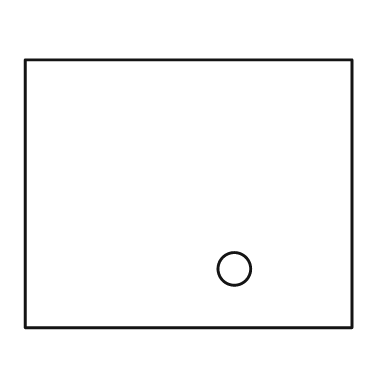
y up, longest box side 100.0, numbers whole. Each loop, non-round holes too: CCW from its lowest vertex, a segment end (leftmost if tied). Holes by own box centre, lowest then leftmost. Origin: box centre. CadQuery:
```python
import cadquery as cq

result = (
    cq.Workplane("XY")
    .moveTo(-50.0, -41.0)
    .lineTo(50.0, -41.0)
    .lineTo(50.0, 41.0)
    .lineTo(-50.0, 41.0)
    .close()
    .moveTo(14.0, -23.0)
    .circle(5.0)
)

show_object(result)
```